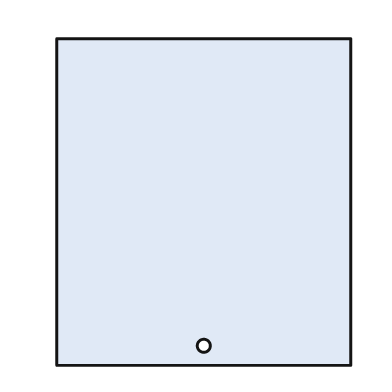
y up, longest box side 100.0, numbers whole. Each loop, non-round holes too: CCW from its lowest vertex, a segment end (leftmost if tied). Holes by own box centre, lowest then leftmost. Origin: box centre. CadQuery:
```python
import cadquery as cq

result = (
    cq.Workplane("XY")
    .moveTo(-45.0, -50.0)
    .lineTo(45.0, -50.0)
    .lineTo(45.0, 50.0)
    .lineTo(-45.0, 50.0)
    .close()
    .moveTo(0.0, -44.0)
    .circle(2.0)
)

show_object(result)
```